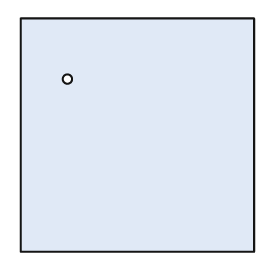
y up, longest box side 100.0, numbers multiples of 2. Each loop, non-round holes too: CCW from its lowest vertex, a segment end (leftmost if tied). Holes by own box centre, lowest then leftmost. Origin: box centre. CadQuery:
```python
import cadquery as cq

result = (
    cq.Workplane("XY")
    .moveTo(-50.0, -50.0)
    .lineTo(50.0, -50.0)
    .lineTo(50.0, 50.0)
    .lineTo(-50.0, 50.0)
    .close()
    .moveTo(-30.0, 24.0)
    .circle(2.0)
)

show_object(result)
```